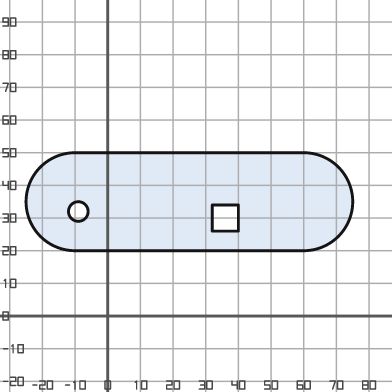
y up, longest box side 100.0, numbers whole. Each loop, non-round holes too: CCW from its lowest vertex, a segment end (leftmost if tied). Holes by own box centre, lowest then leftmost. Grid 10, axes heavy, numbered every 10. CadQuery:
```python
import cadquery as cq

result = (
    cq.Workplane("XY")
    .moveTo(-10.0, 20.0)
    .lineTo(60.0, 20.0)
    .threePointArc((75.0, 35.0), (60.0, 50.0))
    .lineTo(-10.0, 50.0)
    .threePointArc((-25.0, 35.0), (-10.0, 20.0))
    .close()
    .moveTo(32.0, 26.0)
    .lineTo(40.0, 26.0)
    .lineTo(40.0, 34.0)
    .lineTo(32.0, 34.0)
    .close()
    .moveTo(-9.0, 32.0)
    .circle(3.0)
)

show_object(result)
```